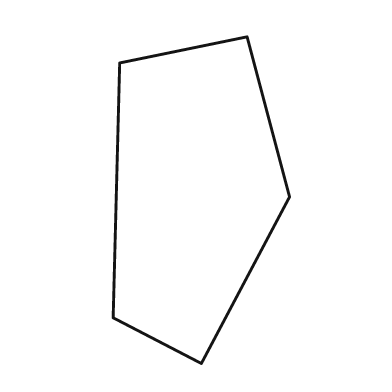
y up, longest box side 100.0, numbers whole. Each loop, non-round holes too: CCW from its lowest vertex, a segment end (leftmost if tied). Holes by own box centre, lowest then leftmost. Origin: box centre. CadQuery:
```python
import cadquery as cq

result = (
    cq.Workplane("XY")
    .moveTo(0.0, -50.0)
    .lineTo(27.0, 1.0)
    .lineTo(14.0, 50.0)
    .lineTo(-25.0, 42.0)
    .lineTo(-27.0, -36.0)
    .close()
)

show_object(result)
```